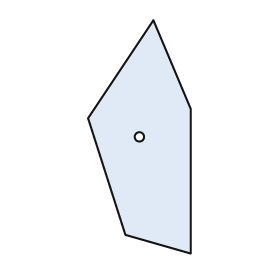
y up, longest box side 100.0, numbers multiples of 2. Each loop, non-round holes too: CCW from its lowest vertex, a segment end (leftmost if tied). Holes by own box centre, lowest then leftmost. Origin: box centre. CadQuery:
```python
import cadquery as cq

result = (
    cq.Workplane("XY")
    .moveTo(22.0, -50.0)
    .lineTo(22.0, 12.0)
    .lineTo(6.0, 50.0)
    .lineTo(-22.0, 8.0)
    .lineTo(-6.0, -42.0)
    .close()
    .moveTo(0.0, 0.0)
    .circle(2.0)
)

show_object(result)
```